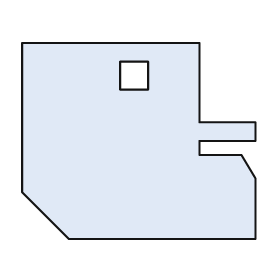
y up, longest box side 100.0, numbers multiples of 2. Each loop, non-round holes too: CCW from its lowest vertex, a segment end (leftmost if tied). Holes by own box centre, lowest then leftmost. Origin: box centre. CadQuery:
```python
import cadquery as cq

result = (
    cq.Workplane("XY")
    .moveTo(-30.0, -42.0)
    .lineTo(50.0, -42.0)
    .lineTo(50.0, -16.0)
    .lineTo(44.0, -6.0)
    .lineTo(26.0, -6.0)
    .lineTo(26.0, 0.0)
    .lineTo(50.0, 0.0)
    .lineTo(50.0, 8.0)
    .lineTo(26.0, 8.0)
    .lineTo(26.0, 42.0)
    .lineTo(-50.0, 42.0)
    .lineTo(-50.0, -22.0)
    .close()
    .moveTo(-8.0, 22.0)
    .lineTo(4.0, 22.0)
    .lineTo(4.0, 34.0)
    .lineTo(-8.0, 34.0)
    .close()
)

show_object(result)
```